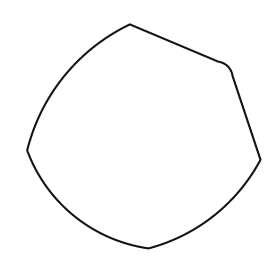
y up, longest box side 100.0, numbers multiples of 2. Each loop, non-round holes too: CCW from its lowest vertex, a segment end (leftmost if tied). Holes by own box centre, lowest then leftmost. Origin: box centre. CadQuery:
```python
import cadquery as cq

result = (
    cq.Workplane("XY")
    .moveTo(2.0, -48.0)
    .threePointArc((30.0, -34.0), (50.0, -10.0))
    .lineTo(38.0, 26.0)
    .threePointArc((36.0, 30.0), (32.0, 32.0))
    .lineTo(-6.0, 48.0)
    .threePointArc((-34.0, 26.0), (-50.0, -6.0))
    .threePointArc((-30.0, -34.0), (2.0, -48.0))
    .close()
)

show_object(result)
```